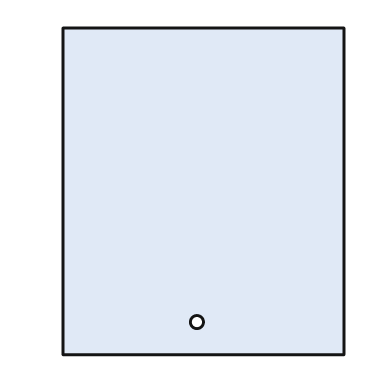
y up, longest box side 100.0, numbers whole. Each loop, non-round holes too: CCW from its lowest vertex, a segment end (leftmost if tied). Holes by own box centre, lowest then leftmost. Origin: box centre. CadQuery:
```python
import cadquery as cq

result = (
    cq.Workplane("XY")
    .moveTo(-43.0, -50.0)
    .lineTo(43.0, -50.0)
    .lineTo(43.0, 50.0)
    .lineTo(-43.0, 50.0)
    .close()
    .moveTo(-2.0, -40.0)
    .circle(2.0)
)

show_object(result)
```